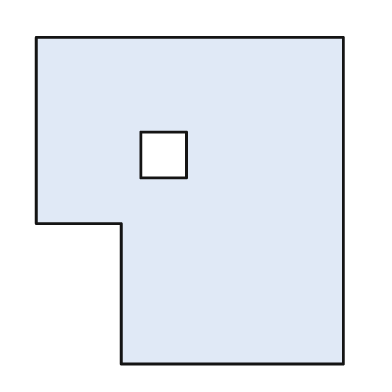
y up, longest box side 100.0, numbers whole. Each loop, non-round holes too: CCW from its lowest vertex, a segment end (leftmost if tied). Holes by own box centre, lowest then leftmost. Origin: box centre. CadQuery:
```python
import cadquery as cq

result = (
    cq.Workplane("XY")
    .moveTo(-21.0, -50.0)
    .lineTo(47.0, -50.0)
    .lineTo(47.0, 50.0)
    .lineTo(-47.0, 50.0)
    .lineTo(-47.0, -7.0)
    .lineTo(-21.0, -7.0)
    .close()
    .moveTo(-15.0, 7.0)
    .lineTo(-1.0, 7.0)
    .lineTo(-1.0, 21.0)
    .lineTo(-15.0, 21.0)
    .close()
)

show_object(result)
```